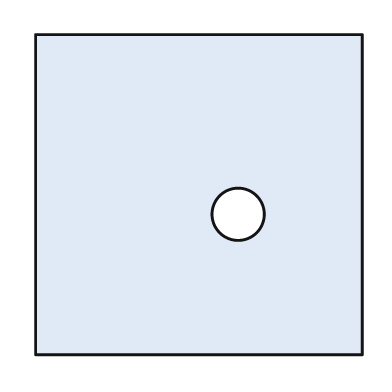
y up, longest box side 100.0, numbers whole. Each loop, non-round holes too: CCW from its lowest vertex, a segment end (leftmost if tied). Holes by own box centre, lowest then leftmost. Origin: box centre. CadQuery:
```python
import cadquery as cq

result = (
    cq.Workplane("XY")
    .moveTo(-50.0, -49.0)
    .lineTo(50.0, -49.0)
    .lineTo(50.0, 49.0)
    .lineTo(-50.0, 49.0)
    .close()
    .moveTo(12.0, -6.0)
    .circle(8.0)
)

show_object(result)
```